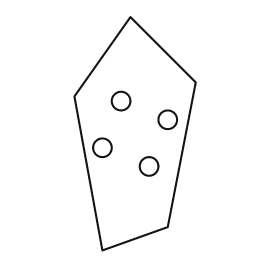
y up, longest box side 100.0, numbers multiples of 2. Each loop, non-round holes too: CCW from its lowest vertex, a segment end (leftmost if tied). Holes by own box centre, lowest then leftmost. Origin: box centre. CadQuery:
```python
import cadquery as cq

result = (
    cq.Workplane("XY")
    .moveTo(-14.0, -50.0)
    .lineTo(14.0, -40.0)
    .lineTo(26.0, 22.0)
    .lineTo(-2.0, 50.0)
    .lineTo(-26.0, 16.0)
    .close()
    .moveTo(6.0, -14.0)
    .circle(4.0)
    .moveTo(-14.0, -6.0)
    .circle(4.0)
    .moveTo(14.0, 6.0)
    .circle(4.0)
    .moveTo(-6.0, 14.0)
    .circle(4.0)
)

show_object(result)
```